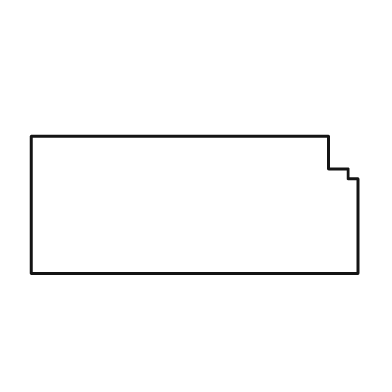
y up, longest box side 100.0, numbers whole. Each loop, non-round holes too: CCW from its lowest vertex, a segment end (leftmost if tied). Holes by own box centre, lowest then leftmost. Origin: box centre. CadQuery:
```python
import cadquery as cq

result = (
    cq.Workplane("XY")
    .moveTo(-50.0, -21.0)
    .lineTo(50.0, -21.0)
    .lineTo(50.0, 8.0)
    .lineTo(47.0, 8.0)
    .lineTo(47.0, 11.0)
    .lineTo(41.0, 11.0)
    .lineTo(41.0, 21.0)
    .lineTo(-50.0, 21.0)
    .close()
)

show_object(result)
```